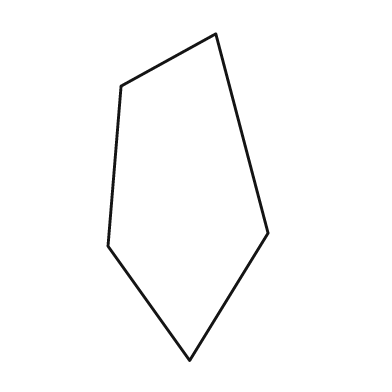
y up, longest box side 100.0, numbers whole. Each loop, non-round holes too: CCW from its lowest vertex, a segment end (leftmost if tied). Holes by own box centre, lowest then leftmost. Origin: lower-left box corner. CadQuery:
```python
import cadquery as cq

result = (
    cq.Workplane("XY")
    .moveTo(25.0, 0.0)
    .lineTo(49.0, 39.0)
    .lineTo(33.0, 100.0)
    .lineTo(4.0, 84.0)
    .lineTo(0.0, 35.0)
    .close()
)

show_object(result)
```